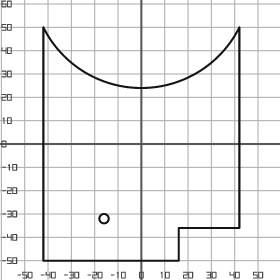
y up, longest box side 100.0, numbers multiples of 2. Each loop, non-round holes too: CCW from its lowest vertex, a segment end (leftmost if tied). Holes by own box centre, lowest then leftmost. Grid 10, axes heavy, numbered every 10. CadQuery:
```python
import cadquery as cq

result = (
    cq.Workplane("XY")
    .moveTo(-42.0, -50.0)
    .lineTo(16.0, -50.0)
    .lineTo(16.0, -36.0)
    .lineTo(42.0, -36.0)
    .lineTo(42.0, 50.0)
    .threePointArc((0.0, 24.0), (-42.0, 50.0))
    .close()
    .moveTo(-16.0, -32.0)
    .circle(2.0)
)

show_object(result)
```